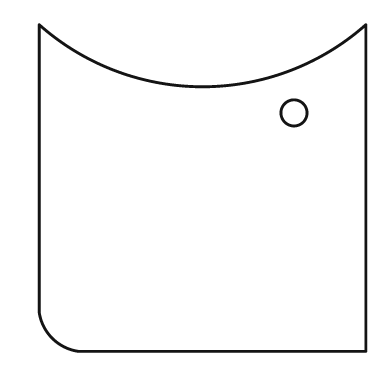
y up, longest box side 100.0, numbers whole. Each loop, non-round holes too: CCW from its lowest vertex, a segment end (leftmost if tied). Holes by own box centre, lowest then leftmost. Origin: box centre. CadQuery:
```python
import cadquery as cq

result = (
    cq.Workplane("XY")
    .moveTo(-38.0, -50.0)
    .lineTo(50.0, -50.0)
    .lineTo(50.0, 50.0)
    .threePointArc((0.0, 31.0), (-50.0, 50.0))
    .lineTo(-50.0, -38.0)
    .threePointArc((-46.0, -46.0), (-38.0, -50.0))
    .close()
    .moveTo(28.0, 23.0)
    .circle(4.0)
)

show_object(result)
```